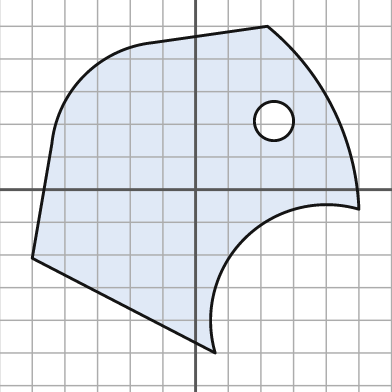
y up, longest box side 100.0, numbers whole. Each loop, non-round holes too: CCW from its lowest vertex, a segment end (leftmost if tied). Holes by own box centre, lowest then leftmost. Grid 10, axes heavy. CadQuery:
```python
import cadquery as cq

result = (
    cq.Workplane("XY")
    .moveTo(6.0, -50.0)
    .threePointArc((15.0, -15.0), (50.0, -6.0))
    .threePointArc((42.0, 25.0), (22.0, 50.0))
    .lineTo(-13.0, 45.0)
    .threePointArc((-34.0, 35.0), (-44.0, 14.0))
    .lineTo(-50.0, -21.0)
    .close()
    .moveTo(24.0, 21.0)
    .circle(6.0)
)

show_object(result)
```